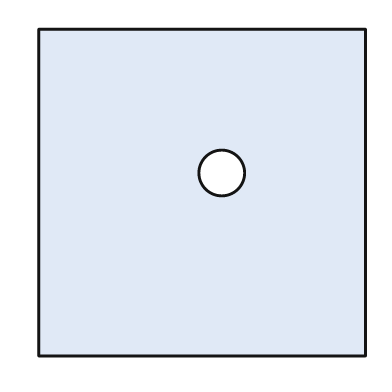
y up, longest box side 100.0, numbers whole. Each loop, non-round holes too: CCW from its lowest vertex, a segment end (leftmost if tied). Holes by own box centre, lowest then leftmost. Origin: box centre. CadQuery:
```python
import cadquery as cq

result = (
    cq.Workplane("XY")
    .moveTo(-50.0, -50.0)
    .lineTo(50.0, -50.0)
    .lineTo(50.0, 50.0)
    .lineTo(-50.0, 50.0)
    .close()
    .moveTo(6.0, 6.0)
    .circle(7.0)
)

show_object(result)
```